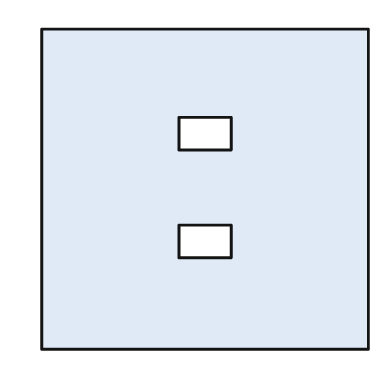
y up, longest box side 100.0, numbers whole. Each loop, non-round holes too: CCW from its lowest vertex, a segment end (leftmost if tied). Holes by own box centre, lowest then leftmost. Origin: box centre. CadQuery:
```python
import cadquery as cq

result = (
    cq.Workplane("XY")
    .moveTo(-50.0, -49.0)
    .lineTo(50.0, -49.0)
    .lineTo(50.0, 49.0)
    .lineTo(-50.0, 49.0)
    .close()
    .moveTo(-8.0, -21.0)
    .lineTo(8.0, -21.0)
    .lineTo(8.0, -11.0)
    .lineTo(-8.0, -11.0)
    .close()
    .moveTo(-8.0, 12.0)
    .lineTo(8.0, 12.0)
    .lineTo(8.0, 22.0)
    .lineTo(-8.0, 22.0)
    .close()
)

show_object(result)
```